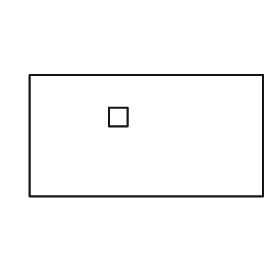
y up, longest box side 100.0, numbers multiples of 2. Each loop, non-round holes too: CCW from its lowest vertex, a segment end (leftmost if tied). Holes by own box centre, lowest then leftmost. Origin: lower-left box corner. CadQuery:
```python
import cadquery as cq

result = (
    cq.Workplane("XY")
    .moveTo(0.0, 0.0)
    .lineTo(100.0, 0.0)
    .lineTo(100.0, 52.0)
    .lineTo(0.0, 52.0)
    .close()
    .moveTo(34.0, 30.0)
    .lineTo(42.0, 30.0)
    .lineTo(42.0, 38.0)
    .lineTo(34.0, 38.0)
    .close()
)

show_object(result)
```